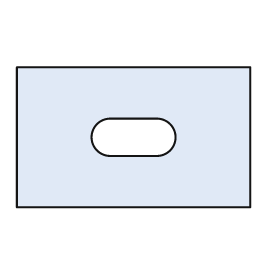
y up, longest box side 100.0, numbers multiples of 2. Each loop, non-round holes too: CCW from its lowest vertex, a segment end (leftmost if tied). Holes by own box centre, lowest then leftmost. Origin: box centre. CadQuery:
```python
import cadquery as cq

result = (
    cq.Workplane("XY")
    .moveTo(-50.0, -30.0)
    .lineTo(50.0, -30.0)
    .lineTo(50.0, 30.0)
    .lineTo(-50.0, 30.0)
    .close()
    .moveTo(-10.0, -8.0)
    .lineTo(10.0, -8.0)
    .threePointArc((18.0, 0.0), (10.0, 8.0))
    .lineTo(-10.0, 8.0)
    .threePointArc((-18.0, 0.0), (-10.0, -8.0))
    .close()
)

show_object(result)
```